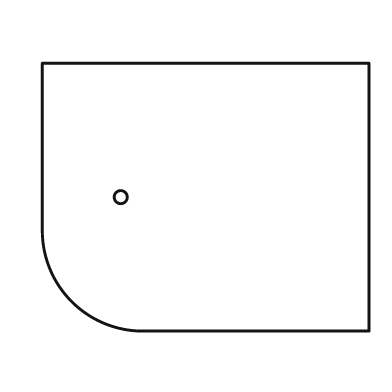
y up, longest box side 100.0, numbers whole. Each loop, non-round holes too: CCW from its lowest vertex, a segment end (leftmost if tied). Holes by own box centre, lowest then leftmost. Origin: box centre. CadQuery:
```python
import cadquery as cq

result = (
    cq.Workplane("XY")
    .moveTo(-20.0, -41.0)
    .lineTo(50.0, -41.0)
    .lineTo(50.0, 41.0)
    .lineTo(-50.0, 41.0)
    .lineTo(-50.0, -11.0)
    .threePointArc((-41.0, -32.0), (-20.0, -41.0))
    .close()
    .moveTo(-26.0, 0.0)
    .circle(2.0)
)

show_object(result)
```